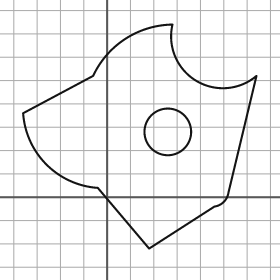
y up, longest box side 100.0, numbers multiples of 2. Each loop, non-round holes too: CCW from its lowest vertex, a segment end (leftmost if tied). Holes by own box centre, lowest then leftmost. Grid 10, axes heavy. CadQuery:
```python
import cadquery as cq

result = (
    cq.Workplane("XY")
    .moveTo(18.0, -22.0)
    .lineTo(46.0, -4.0)
    .threePointArc((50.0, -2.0), (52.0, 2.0))
    .lineTo(64.0, 52.0)
    .threePointArc((38.0, 50.0), (28.0, 74.0))
    .threePointArc((8.0, 68.0), (-6.0, 52.0))
    .lineTo(-36.0, 36.0)
    .threePointArc((-26.0, 14.0), (-4.0, 4.0))
    .close()
    .moveTo(26.0, 28.0)
    .circle(10.0)
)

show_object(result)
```